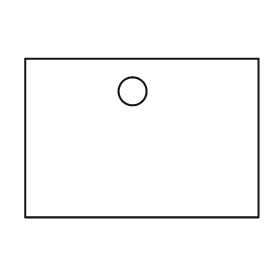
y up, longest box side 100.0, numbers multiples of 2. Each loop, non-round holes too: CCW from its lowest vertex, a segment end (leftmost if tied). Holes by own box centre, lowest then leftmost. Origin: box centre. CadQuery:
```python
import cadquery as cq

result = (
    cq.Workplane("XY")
    .moveTo(-50.0, -34.0)
    .lineTo(50.0, -34.0)
    .lineTo(50.0, 34.0)
    .lineTo(-50.0, 34.0)
    .close()
    .moveTo(-4.0, 20.0)
    .circle(6.0)
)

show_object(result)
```